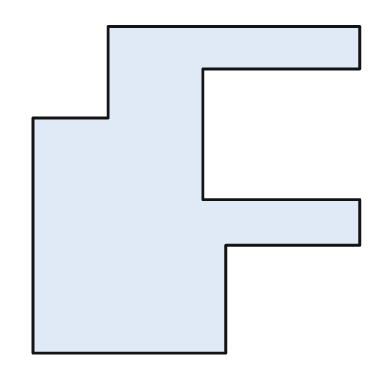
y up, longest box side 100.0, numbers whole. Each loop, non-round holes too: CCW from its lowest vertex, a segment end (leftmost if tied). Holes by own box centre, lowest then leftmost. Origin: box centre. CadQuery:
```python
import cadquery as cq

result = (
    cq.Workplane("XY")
    .moveTo(-50.0, -50.0)
    .lineTo(9.0, -50.0)
    .lineTo(9.0, -17.0)
    .lineTo(50.0, -17.0)
    .lineTo(50.0, -3.0)
    .lineTo(2.0, -3.0)
    .lineTo(2.0, 37.0)
    .lineTo(50.0, 37.0)
    .lineTo(50.0, 50.0)
    .lineTo(-27.0, 50.0)
    .lineTo(-27.0, 22.0)
    .lineTo(-50.0, 22.0)
    .close()
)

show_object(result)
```